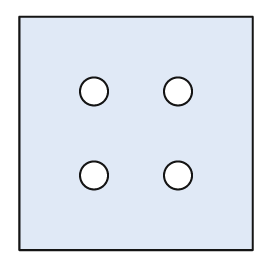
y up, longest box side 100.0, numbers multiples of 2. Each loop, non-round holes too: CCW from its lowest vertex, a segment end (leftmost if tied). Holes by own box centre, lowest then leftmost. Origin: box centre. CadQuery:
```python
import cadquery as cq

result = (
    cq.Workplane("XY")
    .moveTo(-50.0, -50.0)
    .lineTo(50.0, -50.0)
    .lineTo(50.0, 50.0)
    .lineTo(-50.0, 50.0)
    .close()
    .moveTo(-18.0, -18.0)
    .circle(6.0)
    .moveTo(18.0, -18.0)
    .circle(6.0)
    .moveTo(-18.0, 18.0)
    .circle(6.0)
    .moveTo(18.0, 18.0)
    .circle(6.0)
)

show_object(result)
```